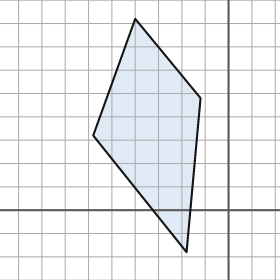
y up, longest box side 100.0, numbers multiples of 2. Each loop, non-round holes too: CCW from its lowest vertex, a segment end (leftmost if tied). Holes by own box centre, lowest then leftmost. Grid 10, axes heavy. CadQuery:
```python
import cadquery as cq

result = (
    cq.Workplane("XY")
    .moveTo(-18.0, -18.0)
    .lineTo(-12.0, 48.0)
    .lineTo(-40.0, 82.0)
    .lineTo(-58.0, 32.0)
    .close()
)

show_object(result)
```